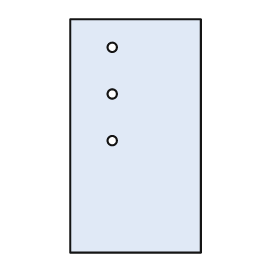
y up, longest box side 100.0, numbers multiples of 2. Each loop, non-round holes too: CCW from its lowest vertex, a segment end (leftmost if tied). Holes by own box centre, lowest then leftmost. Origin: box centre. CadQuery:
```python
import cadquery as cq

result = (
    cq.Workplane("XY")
    .moveTo(-28.0, -50.0)
    .lineTo(28.0, -50.0)
    .lineTo(28.0, 50.0)
    .lineTo(-28.0, 50.0)
    .close()
    .moveTo(-10.0, -2.0)
    .circle(2.0)
    .moveTo(-10.0, 18.0)
    .circle(2.0)
    .moveTo(-10.0, 38.0)
    .circle(2.0)
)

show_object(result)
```